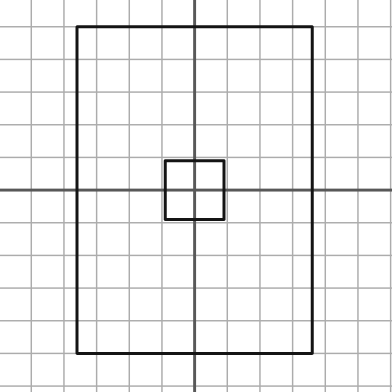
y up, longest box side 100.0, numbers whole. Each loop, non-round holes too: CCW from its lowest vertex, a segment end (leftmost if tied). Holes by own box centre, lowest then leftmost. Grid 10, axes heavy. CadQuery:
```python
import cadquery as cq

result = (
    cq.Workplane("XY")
    .moveTo(-36.0, -50.0)
    .lineTo(36.0, -50.0)
    .lineTo(36.0, 50.0)
    .lineTo(-36.0, 50.0)
    .close()
    .moveTo(-9.0, -9.0)
    .lineTo(9.0, -9.0)
    .lineTo(9.0, 9.0)
    .lineTo(-9.0, 9.0)
    .close()
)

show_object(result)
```